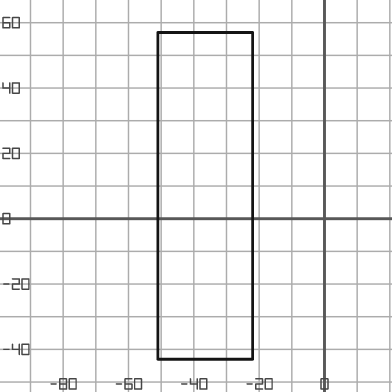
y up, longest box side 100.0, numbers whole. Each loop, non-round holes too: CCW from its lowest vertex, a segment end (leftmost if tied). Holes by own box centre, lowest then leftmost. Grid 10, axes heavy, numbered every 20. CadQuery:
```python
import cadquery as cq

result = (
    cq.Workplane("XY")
    .moveTo(-51.0, -43.0)
    .lineTo(-22.0, -43.0)
    .lineTo(-22.0, 57.0)
    .lineTo(-51.0, 57.0)
    .close()
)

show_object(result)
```